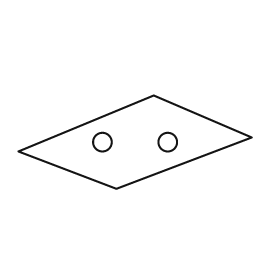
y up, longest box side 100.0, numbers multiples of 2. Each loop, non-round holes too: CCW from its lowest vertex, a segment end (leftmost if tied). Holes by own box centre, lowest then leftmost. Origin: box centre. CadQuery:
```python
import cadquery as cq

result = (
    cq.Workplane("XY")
    .moveTo(-8.0, -20.0)
    .lineTo(50.0, 2.0)
    .lineTo(8.0, 20.0)
    .lineTo(-50.0, -4.0)
    .close()
    .moveTo(-14.0, 0.0)
    .circle(4.0)
    .moveTo(14.0, 0.0)
    .circle(4.0)
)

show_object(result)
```